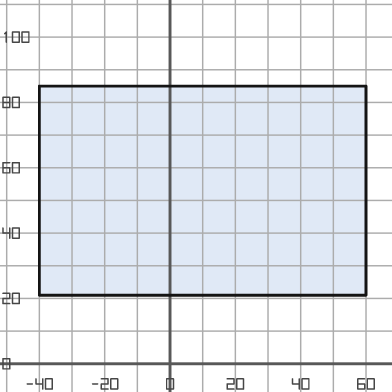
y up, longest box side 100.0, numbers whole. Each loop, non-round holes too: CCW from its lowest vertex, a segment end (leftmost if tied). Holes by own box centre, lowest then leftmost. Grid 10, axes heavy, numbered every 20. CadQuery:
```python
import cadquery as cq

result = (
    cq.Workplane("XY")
    .moveTo(-40.0, 21.0)
    .lineTo(60.0, 21.0)
    .lineTo(60.0, 85.0)
    .lineTo(-40.0, 85.0)
    .close()
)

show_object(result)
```